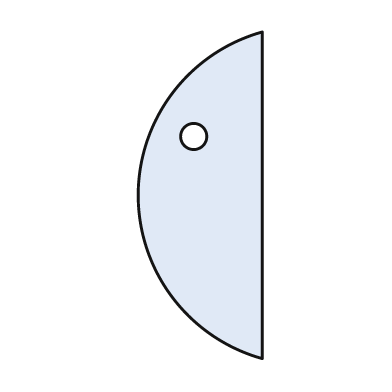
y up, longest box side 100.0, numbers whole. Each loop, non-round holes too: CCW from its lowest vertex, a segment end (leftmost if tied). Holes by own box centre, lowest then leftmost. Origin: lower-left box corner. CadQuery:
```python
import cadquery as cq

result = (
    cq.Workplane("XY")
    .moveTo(38.0, 0.0)
    .lineTo(38.0, 100.0)
    .threePointArc((0.0, 50.0), (38.0, 0.0))
    .close()
    .moveTo(17.0, 68.0)
    .circle(4.0)
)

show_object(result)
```